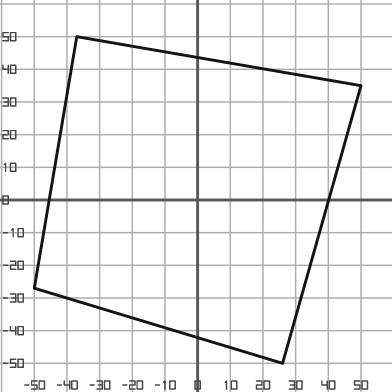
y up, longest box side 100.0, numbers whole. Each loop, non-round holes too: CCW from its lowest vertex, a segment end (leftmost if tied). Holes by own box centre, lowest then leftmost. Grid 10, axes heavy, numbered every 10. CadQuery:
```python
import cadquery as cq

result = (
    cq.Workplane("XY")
    .moveTo(26.0, -50.0)
    .lineTo(50.0, 35.0)
    .lineTo(-37.0, 50.0)
    .lineTo(-50.0, -27.0)
    .close()
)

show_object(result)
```